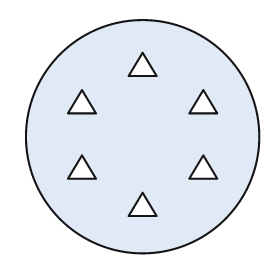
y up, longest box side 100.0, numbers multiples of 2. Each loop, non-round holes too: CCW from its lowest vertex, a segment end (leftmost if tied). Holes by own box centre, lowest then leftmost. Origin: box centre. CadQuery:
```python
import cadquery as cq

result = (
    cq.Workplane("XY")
    .moveTo(0.0, 0.0)
    .circle(50.0)
    .moveTo(-6.0, -34.0)
    .lineTo(6.0, -34.0)
    .lineTo(0.0, -24.0)
    .close()
    .moveTo(-32.0, -18.0)
    .lineTo(-20.0, -18.0)
    .lineTo(-26.0, -8.0)
    .close()
    .moveTo(20.0, -18.0)
    .lineTo(32.0, -18.0)
    .lineTo(26.0, -8.0)
    .close()
    .moveTo(-32.0, 10.0)
    .lineTo(-20.0, 10.0)
    .lineTo(-26.0, 20.0)
    .close()
    .moveTo(20.0, 10.0)
    .lineTo(32.0, 10.0)
    .lineTo(26.0, 20.0)
    .close()
    .moveTo(-6.0, 26.0)
    .lineTo(6.0, 26.0)
    .lineTo(0.0, 36.0)
    .close()
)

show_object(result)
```